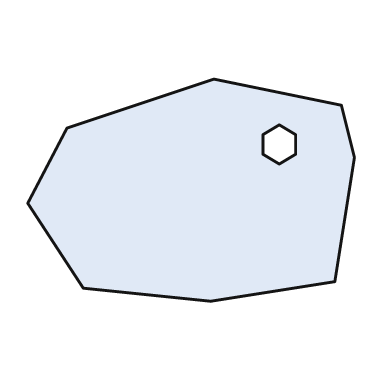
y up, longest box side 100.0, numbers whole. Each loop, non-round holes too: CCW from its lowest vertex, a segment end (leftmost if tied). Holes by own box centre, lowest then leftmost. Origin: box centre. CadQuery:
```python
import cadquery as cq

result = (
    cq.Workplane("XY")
    .moveTo(6.0, -34.0)
    .lineTo(44.0, -28.0)
    .lineTo(50.0, 10.0)
    .lineTo(46.0, 26.0)
    .lineTo(7.0, 34.0)
    .lineTo(-38.0, 19.0)
    .lineTo(-50.0, -4.0)
    .lineTo(-33.0, -30.0)
    .close()
    .moveTo(27.0, 8.0)
    .lineTo(32.0, 11.0)
    .lineTo(32.0, 17.0)
    .lineTo(27.0, 20.0)
    .lineTo(22.0, 17.0)
    .lineTo(22.0, 11.0)
    .close()
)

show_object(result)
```